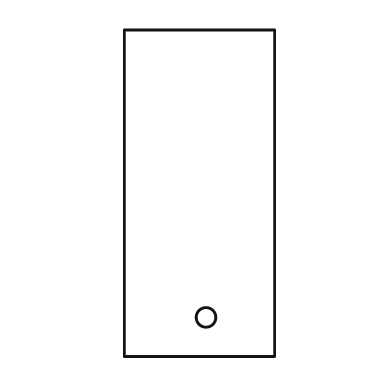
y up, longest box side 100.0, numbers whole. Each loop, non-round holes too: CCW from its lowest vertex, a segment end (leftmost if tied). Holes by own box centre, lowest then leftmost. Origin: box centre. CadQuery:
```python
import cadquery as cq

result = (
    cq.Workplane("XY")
    .moveTo(-23.0, -50.0)
    .lineTo(23.0, -50.0)
    .lineTo(23.0, 50.0)
    .lineTo(-23.0, 50.0)
    .close()
    .moveTo(2.0, -38.0)
    .circle(3.0)
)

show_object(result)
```